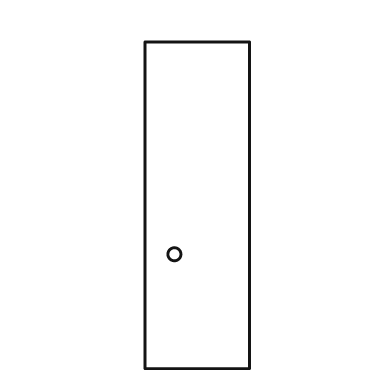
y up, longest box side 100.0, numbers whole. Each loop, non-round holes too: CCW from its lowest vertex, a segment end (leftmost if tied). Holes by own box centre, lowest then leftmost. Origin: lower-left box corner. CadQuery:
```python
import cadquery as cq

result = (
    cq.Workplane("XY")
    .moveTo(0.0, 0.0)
    .lineTo(32.0, 0.0)
    .lineTo(32.0, 100.0)
    .lineTo(0.0, 100.0)
    .close()
    .moveTo(9.0, 35.0)
    .circle(2.0)
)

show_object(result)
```